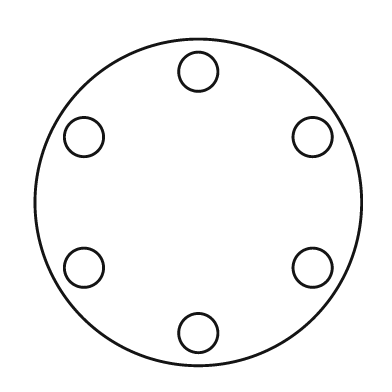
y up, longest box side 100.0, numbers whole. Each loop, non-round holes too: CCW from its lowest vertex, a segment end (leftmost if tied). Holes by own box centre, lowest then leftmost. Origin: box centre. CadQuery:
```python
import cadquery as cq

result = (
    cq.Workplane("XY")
    .moveTo(0.0, 0.0)
    .circle(50.0)
    .moveTo(0.0, -40.0)
    .circle(6.0)
    .moveTo(-35.0, -20.0)
    .circle(6.0)
    .moveTo(35.0, -20.0)
    .circle(6.0)
    .moveTo(-35.0, 20.0)
    .circle(6.0)
    .moveTo(35.0, 20.0)
    .circle(6.0)
    .moveTo(0.0, 40.0)
    .circle(6.0)
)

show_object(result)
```